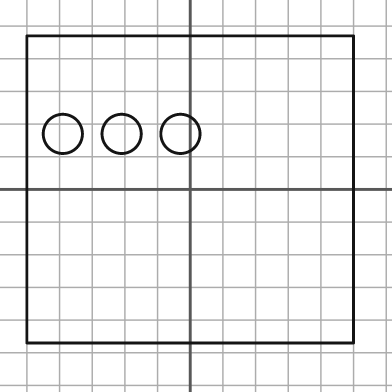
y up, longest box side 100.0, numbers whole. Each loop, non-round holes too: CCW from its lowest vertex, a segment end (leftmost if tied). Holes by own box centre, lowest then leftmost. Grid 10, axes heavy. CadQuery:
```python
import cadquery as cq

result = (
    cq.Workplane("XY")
    .moveTo(-50.0, -47.0)
    .lineTo(50.0, -47.0)
    .lineTo(50.0, 47.0)
    .lineTo(-50.0, 47.0)
    .close()
    .moveTo(-39.0, 17.0)
    .circle(6.0)
    .moveTo(-21.0, 17.0)
    .circle(6.0)
    .moveTo(-3.0, 17.0)
    .circle(6.0)
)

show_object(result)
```